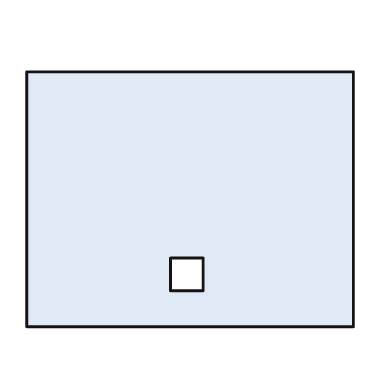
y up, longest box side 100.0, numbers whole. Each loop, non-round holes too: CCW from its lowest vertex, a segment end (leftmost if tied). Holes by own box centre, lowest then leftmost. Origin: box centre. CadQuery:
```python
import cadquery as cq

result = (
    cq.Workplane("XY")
    .moveTo(-50.0, -39.0)
    .lineTo(50.0, -39.0)
    .lineTo(50.0, 39.0)
    .lineTo(-50.0, 39.0)
    .close()
    .moveTo(-6.0, -28.0)
    .lineTo(4.0, -28.0)
    .lineTo(4.0, -18.0)
    .lineTo(-6.0, -18.0)
    .close()
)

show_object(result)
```